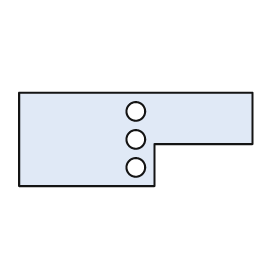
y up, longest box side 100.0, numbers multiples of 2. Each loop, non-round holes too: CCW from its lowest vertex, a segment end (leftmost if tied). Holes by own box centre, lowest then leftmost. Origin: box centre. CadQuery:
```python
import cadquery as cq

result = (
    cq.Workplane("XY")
    .moveTo(-50.0, -20.0)
    .lineTo(8.0, -20.0)
    .lineTo(8.0, -2.0)
    .lineTo(50.0, -2.0)
    .lineTo(50.0, 20.0)
    .lineTo(-50.0, 20.0)
    .close()
    .moveTo(0.0, -12.0)
    .circle(4.0)
    .moveTo(0.0, 0.0)
    .circle(4.0)
    .moveTo(0.0, 12.0)
    .circle(4.0)
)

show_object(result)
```